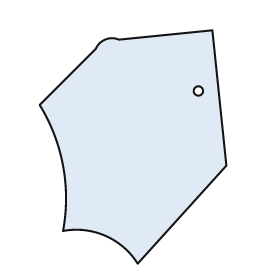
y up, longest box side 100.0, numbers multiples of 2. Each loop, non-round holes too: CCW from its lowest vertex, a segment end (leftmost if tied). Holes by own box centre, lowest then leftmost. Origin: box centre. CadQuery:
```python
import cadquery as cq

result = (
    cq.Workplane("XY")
    .moveTo(2.0, -50.0)
    .lineTo(40.0, -8.0)
    .lineTo(34.0, 50.0)
    .lineTo(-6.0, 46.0)
    .threePointArc((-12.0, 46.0), (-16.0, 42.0))
    .lineTo(-40.0, 18.0)
    .threePointArc((-30.0, -8.0), (-30.0, -36.0))
    .threePointArc((-12.0, -38.0), (2.0, -50.0))
    .close()
    .moveTo(28.0, 24.0)
    .circle(2.0)
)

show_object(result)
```